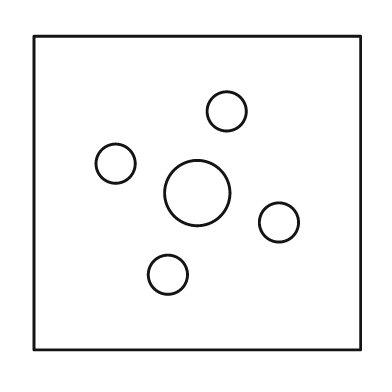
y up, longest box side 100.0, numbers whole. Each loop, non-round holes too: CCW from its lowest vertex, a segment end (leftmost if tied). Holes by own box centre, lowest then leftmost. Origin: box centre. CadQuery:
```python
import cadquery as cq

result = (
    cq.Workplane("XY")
    .moveTo(-50.0, -48.0)
    .lineTo(50.0, -48.0)
    .lineTo(50.0, 48.0)
    .lineTo(-50.0, 48.0)
    .close()
    .moveTo(-9.0, -25.0)
    .circle(6.0)
    .moveTo(25.0, -9.0)
    .circle(6.0)
    .moveTo(0.0, 0.0)
    .circle(10.0)
    .moveTo(-25.0, 9.0)
    .circle(6.0)
    .moveTo(9.0, 25.0)
    .circle(6.0)
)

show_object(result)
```